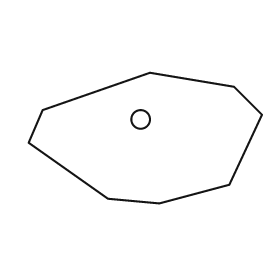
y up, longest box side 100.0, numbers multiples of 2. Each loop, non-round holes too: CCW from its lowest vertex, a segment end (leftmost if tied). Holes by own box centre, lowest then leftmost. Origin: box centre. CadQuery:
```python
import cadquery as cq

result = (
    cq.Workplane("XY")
    .moveTo(6.0, -28.0)
    .lineTo(36.0, -20.0)
    .lineTo(50.0, 10.0)
    .lineTo(38.0, 22.0)
    .lineTo(2.0, 28.0)
    .lineTo(-44.0, 12.0)
    .lineTo(-50.0, -2.0)
    .lineTo(-16.0, -26.0)
    .close()
    .moveTo(-2.0, 8.0)
    .circle(4.0)
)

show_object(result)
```